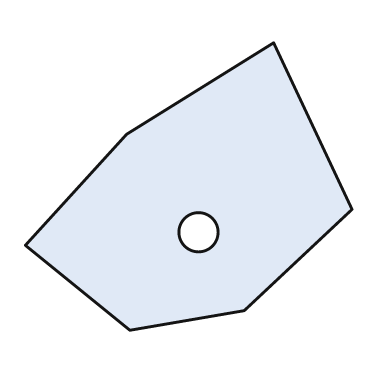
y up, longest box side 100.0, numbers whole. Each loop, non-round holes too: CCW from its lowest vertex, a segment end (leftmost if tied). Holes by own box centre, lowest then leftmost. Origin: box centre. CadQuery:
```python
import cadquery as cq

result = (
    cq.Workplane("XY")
    .moveTo(-18.0, -44.0)
    .lineTo(17.0, -38.0)
    .lineTo(50.0, -7.0)
    .lineTo(26.0, 44.0)
    .lineTo(-19.0, 16.0)
    .lineTo(-50.0, -18.0)
    .close()
    .moveTo(3.0, -14.0)
    .circle(6.0)
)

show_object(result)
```